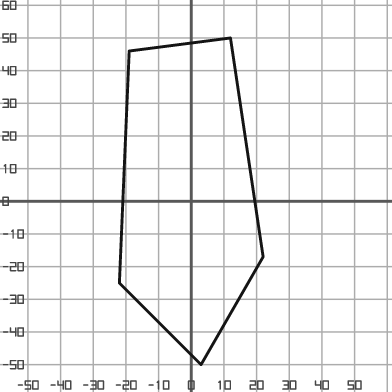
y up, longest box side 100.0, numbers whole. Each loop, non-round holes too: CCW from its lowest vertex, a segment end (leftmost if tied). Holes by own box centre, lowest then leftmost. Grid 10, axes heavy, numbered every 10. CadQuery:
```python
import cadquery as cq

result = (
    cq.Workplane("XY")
    .moveTo(3.0, -50.0)
    .lineTo(22.0, -17.0)
    .lineTo(12.0, 50.0)
    .lineTo(-19.0, 46.0)
    .lineTo(-22.0, -25.0)
    .close()
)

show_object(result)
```